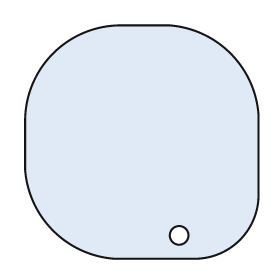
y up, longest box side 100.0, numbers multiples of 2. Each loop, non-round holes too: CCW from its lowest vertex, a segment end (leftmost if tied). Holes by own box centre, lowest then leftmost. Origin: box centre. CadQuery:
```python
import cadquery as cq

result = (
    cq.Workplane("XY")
    .moveTo(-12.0, -50.0)
    .lineTo(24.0, -50.0)
    .threePointArc((42.0, -42.0), (50.0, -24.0))
    .lineTo(50.0, 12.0)
    .threePointArc((38.0, 38.0), (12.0, 50.0))
    .lineTo(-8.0, 50.0)
    .threePointArc((-38.0, 38.0), (-50.0, 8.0))
    .lineTo(-50.0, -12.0)
    .threePointArc((-38.0, -38.0), (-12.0, -50.0))
    .close()
    .moveTo(16.0, -40.0)
    .circle(4.0)
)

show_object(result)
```